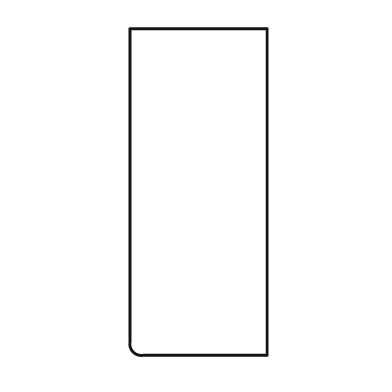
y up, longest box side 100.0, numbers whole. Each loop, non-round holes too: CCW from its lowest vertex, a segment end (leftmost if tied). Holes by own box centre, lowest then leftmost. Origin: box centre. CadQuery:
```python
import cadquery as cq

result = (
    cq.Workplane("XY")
    .moveTo(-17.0, -50.0)
    .lineTo(21.0, -50.0)
    .lineTo(21.0, 50.0)
    .lineTo(-21.0, 50.0)
    .lineTo(-21.0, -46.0)
    .threePointArc((-20.0, -49.0), (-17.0, -50.0))
    .close()
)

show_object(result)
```